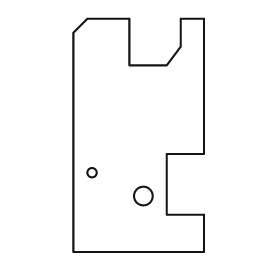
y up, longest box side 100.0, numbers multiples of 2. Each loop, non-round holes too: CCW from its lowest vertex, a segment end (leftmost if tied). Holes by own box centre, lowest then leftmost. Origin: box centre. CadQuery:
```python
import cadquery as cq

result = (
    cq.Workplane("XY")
    .moveTo(-28.0, -50.0)
    .lineTo(28.0, -50.0)
    .lineTo(28.0, -34.0)
    .lineTo(12.0, -34.0)
    .lineTo(12.0, -8.0)
    .lineTo(28.0, -8.0)
    .lineTo(28.0, 50.0)
    .lineTo(18.0, 50.0)
    .lineTo(18.0, 38.0)
    .lineTo(12.0, 30.0)
    .lineTo(-4.0, 30.0)
    .lineTo(-4.0, 50.0)
    .lineTo(-22.0, 50.0)
    .lineTo(-28.0, 44.0)
    .close()
    .moveTo(2.0, -26.0)
    .circle(4.0)
    .moveTo(-20.0, -16.0)
    .circle(2.0)
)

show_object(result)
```